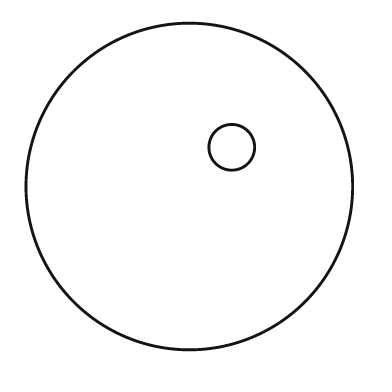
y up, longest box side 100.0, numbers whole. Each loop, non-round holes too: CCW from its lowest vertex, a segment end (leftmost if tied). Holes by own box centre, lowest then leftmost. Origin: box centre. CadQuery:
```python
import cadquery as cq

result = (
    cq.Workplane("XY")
    .moveTo(0.0, 0.0)
    .circle(50.0)
    .moveTo(13.0, 12.0)
    .circle(7.0)
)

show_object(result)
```